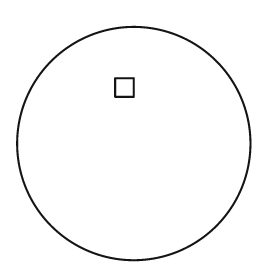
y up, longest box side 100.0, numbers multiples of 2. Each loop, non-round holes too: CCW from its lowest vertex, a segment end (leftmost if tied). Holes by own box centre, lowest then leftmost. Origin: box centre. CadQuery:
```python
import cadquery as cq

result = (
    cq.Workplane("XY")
    .moveTo(0.0, 0.0)
    .circle(50.0)
    .moveTo(-8.0, 20.0)
    .lineTo(0.0, 20.0)
    .lineTo(0.0, 28.0)
    .lineTo(-8.0, 28.0)
    .close()
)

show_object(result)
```